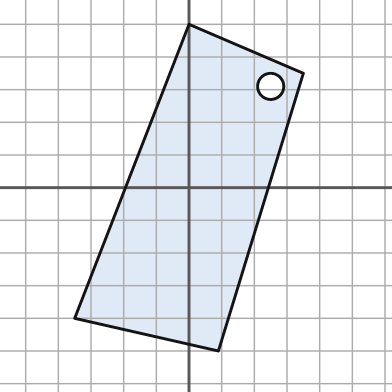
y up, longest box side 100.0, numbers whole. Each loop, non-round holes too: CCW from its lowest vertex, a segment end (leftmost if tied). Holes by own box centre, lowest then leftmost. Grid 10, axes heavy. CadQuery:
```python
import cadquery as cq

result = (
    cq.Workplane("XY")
    .moveTo(9.0, -50.0)
    .lineTo(35.0, 35.0)
    .lineTo(0.0, 50.0)
    .lineTo(-35.0, -40.0)
    .close()
    .moveTo(25.0, 31.0)
    .circle(4.0)
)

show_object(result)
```